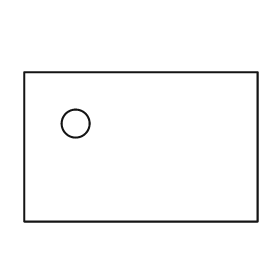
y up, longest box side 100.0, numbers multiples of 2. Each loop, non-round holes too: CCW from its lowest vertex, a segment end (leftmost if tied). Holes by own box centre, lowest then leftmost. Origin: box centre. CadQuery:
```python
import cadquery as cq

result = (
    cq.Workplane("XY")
    .moveTo(-50.0, -32.0)
    .lineTo(50.0, -32.0)
    .lineTo(50.0, 32.0)
    .lineTo(-50.0, 32.0)
    .close()
    .moveTo(-28.0, 10.0)
    .circle(6.0)
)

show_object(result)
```